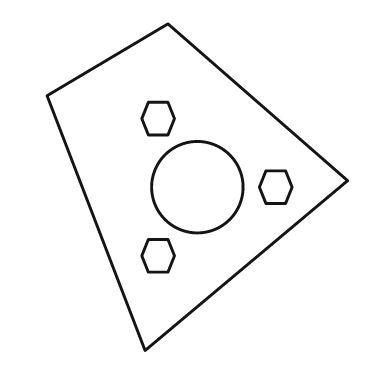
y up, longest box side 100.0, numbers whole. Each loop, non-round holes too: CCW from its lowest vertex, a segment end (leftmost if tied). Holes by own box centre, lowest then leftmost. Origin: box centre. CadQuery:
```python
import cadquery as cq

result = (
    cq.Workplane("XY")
    .moveTo(-16.0, -50.0)
    .lineTo(46.0, 2.0)
    .lineTo(-9.0, 50.0)
    .lineTo(-46.0, 28.0)
    .close()
    .moveTo(-15.0, -26.0)
    .lineTo(-9.0, -26.0)
    .lineTo(-7.0, -21.0)
    .lineTo(-9.0, -16.0)
    .lineTo(-15.0, -16.0)
    .lineTo(-17.0, -21.0)
    .close()
    .moveTo(0.0, 0.0)
    .circle(14.0)
    .moveTo(21.0, -5.0)
    .lineTo(27.0, -5.0)
    .lineTo(29.0, 0.0)
    .lineTo(27.0, 5.0)
    .lineTo(21.0, 5.0)
    .lineTo(19.0, 0.0)
    .close()
    .moveTo(-15.0, 16.0)
    .lineTo(-9.0, 16.0)
    .lineTo(-7.0, 21.0)
    .lineTo(-9.0, 26.0)
    .lineTo(-15.0, 26.0)
    .lineTo(-17.0, 21.0)
    .close()
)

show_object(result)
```